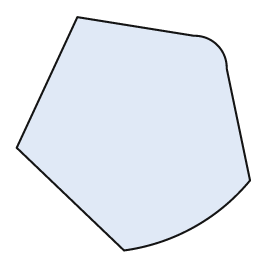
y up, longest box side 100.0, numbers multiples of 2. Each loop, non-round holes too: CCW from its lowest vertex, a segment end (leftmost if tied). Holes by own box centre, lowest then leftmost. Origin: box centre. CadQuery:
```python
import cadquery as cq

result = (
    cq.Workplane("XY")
    .moveTo(-4.0, -50.0)
    .threePointArc((26.0, -40.0), (50.0, -20.0))
    .lineTo(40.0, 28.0)
    .threePointArc((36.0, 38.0), (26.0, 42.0))
    .lineTo(-24.0, 50.0)
    .lineTo(-50.0, -6.0)
    .close()
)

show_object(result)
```